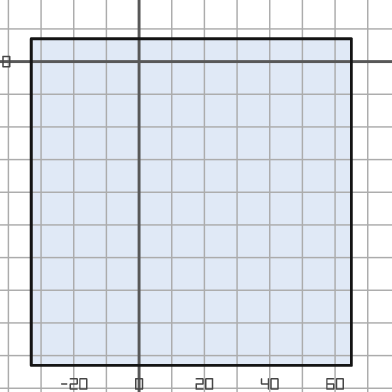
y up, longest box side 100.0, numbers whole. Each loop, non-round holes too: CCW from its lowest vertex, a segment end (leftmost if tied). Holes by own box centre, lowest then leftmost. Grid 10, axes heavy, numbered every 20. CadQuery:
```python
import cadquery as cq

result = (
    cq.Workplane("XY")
    .moveTo(-33.0, -93.0)
    .lineTo(65.0, -93.0)
    .lineTo(65.0, 7.0)
    .lineTo(-33.0, 7.0)
    .close()
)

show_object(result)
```